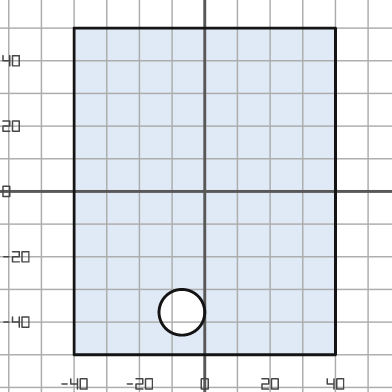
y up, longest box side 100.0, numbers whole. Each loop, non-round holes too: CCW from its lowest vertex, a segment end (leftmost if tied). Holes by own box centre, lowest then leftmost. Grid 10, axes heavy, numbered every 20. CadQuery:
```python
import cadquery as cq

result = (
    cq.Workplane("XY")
    .moveTo(-40.0, -50.0)
    .lineTo(40.0, -50.0)
    .lineTo(40.0, 50.0)
    .lineTo(-40.0, 50.0)
    .close()
    .moveTo(-7.0, -37.0)
    .circle(7.0)
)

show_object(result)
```